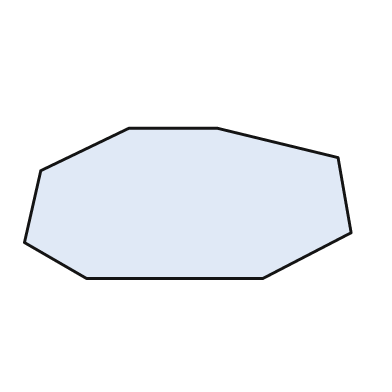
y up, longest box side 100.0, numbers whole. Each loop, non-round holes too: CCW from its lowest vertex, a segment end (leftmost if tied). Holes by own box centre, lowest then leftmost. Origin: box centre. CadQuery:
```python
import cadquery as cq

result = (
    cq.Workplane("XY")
    .moveTo(-31.0, -23.0)
    .lineTo(23.0, -23.0)
    .lineTo(50.0, -9.0)
    .lineTo(46.0, 14.0)
    .lineTo(9.0, 23.0)
    .lineTo(-18.0, 23.0)
    .lineTo(-45.0, 10.0)
    .lineTo(-50.0, -12.0)
    .close()
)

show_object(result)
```